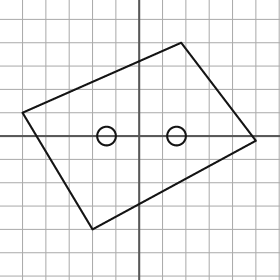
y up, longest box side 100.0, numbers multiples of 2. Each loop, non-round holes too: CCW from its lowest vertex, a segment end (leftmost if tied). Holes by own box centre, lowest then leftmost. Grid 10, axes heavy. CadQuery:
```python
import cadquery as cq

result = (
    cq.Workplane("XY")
    .moveTo(-20.0, -40.0)
    .lineTo(50.0, -2.0)
    .lineTo(18.0, 40.0)
    .lineTo(-50.0, 10.0)
    .close()
    .moveTo(-14.0, 0.0)
    .circle(4.0)
    .moveTo(16.0, 0.0)
    .circle(4.0)
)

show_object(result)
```